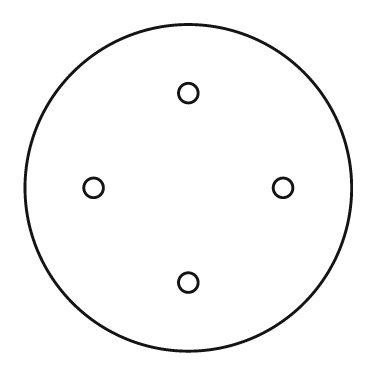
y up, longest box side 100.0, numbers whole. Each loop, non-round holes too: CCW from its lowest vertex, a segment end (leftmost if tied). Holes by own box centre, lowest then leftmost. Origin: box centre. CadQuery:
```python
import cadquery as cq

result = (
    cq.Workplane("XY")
    .moveTo(0.0, 0.0)
    .circle(50.0)
    .moveTo(0.0, -29.0)
    .circle(3.0)
    .moveTo(-29.0, 0.0)
    .circle(3.0)
    .moveTo(29.0, 0.0)
    .circle(3.0)
    .moveTo(0.0, 29.0)
    .circle(3.0)
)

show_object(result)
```